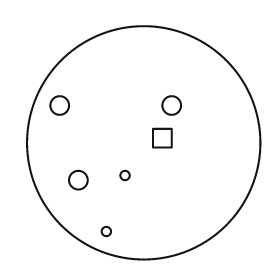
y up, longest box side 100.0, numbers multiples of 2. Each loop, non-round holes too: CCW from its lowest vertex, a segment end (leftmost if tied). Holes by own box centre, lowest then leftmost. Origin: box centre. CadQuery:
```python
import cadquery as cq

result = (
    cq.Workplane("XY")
    .moveTo(0.0, 0.0)
    .circle(50.0)
    .moveTo(-16.0, -38.0)
    .circle(2.0)
    .moveTo(-28.0, -16.0)
    .circle(4.0)
    .moveTo(-8.0, -14.0)
    .circle(2.0)
    .moveTo(4.0, -2.0)
    .lineTo(12.0, -2.0)
    .lineTo(12.0, 6.0)
    .lineTo(4.0, 6.0)
    .close()
    .moveTo(-36.0, 16.0)
    .circle(4.0)
    .moveTo(12.0, 16.0)
    .circle(4.0)
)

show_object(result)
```